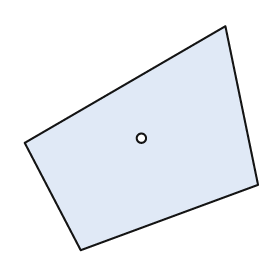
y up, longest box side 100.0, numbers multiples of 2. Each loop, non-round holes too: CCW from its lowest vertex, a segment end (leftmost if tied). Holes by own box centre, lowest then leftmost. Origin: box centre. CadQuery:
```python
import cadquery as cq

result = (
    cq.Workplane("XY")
    .moveTo(-26.0, -48.0)
    .lineTo(50.0, -20.0)
    .lineTo(36.0, 48.0)
    .lineTo(-50.0, -2.0)
    .close()
    .moveTo(0.0, 0.0)
    .circle(2.0)
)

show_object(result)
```